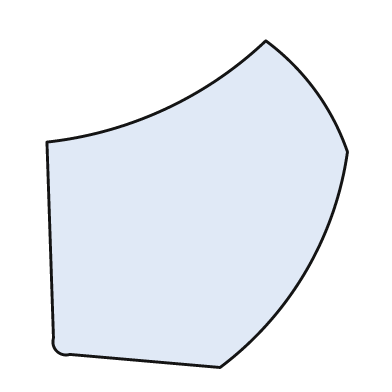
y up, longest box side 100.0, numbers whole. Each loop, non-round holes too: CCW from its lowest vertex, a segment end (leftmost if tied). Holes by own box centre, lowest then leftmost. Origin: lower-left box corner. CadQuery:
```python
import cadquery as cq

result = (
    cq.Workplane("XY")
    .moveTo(53.0, 0.0)
    .threePointArc((79.0, 29.0), (92.0, 66.0))
    .threePointArc((82.0, 85.0), (67.0, 100.0))
    .threePointArc((36.0, 79.0), (0.0, 69.0))
    .lineTo(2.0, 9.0)
    .threePointArc((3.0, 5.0), (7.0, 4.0))
    .close()
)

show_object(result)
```